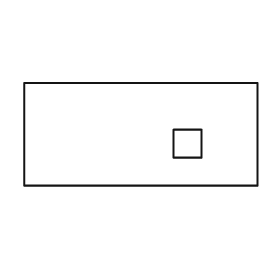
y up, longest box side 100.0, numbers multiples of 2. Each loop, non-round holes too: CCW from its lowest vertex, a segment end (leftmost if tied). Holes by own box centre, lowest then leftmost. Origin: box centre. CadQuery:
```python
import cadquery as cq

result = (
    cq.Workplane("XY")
    .moveTo(-50.0, -22.0)
    .lineTo(50.0, -22.0)
    .lineTo(50.0, 22.0)
    .lineTo(-50.0, 22.0)
    .close()
    .moveTo(14.0, -10.0)
    .lineTo(26.0, -10.0)
    .lineTo(26.0, 2.0)
    .lineTo(14.0, 2.0)
    .close()
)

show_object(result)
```